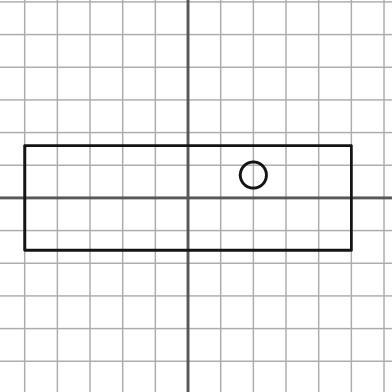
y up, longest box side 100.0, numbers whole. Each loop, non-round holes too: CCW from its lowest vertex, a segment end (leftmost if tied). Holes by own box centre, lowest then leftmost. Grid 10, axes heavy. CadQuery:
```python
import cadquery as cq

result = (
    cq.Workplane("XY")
    .moveTo(-50.0, -16.0)
    .lineTo(50.0, -16.0)
    .lineTo(50.0, 16.0)
    .lineTo(-50.0, 16.0)
    .close()
    .moveTo(20.0, 7.0)
    .circle(4.0)
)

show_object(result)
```